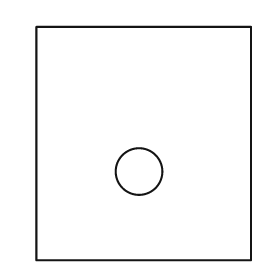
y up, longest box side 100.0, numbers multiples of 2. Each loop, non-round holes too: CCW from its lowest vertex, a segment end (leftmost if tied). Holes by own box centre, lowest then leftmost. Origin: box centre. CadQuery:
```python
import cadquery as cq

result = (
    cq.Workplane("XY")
    .moveTo(-46.0, -50.0)
    .lineTo(46.0, -50.0)
    .lineTo(46.0, 50.0)
    .lineTo(-46.0, 50.0)
    .close()
    .moveTo(-2.0, -12.0)
    .circle(10.0)
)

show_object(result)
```